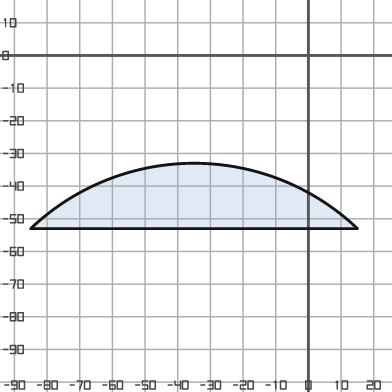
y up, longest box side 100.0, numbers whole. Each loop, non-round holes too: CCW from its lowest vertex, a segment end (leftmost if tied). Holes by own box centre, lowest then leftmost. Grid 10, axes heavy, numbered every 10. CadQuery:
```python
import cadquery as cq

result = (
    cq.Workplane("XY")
    .moveTo(-85.0, -53.0)
    .lineTo(15.0, -53.0)
    .threePointArc((-35.0, -33.0), (-85.0, -53.0))
    .close()
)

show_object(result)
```